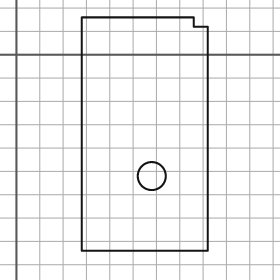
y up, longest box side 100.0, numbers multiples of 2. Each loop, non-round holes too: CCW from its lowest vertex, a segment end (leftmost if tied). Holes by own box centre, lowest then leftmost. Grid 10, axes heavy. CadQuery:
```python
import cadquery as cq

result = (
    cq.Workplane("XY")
    .moveTo(28.0, -84.0)
    .lineTo(82.0, -84.0)
    .lineTo(82.0, 12.0)
    .lineTo(76.0, 12.0)
    .lineTo(76.0, 16.0)
    .lineTo(28.0, 16.0)
    .close()
    .moveTo(58.0, -52.0)
    .circle(6.0)
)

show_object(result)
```